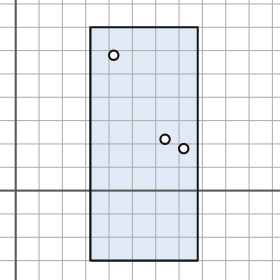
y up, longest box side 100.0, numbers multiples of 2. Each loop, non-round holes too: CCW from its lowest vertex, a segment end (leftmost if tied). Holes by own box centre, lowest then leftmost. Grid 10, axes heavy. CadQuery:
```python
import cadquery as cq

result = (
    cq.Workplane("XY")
    .moveTo(32.0, -30.0)
    .lineTo(78.0, -30.0)
    .lineTo(78.0, 70.0)
    .lineTo(32.0, 70.0)
    .close()
    .moveTo(72.0, 18.0)
    .circle(2.0)
    .moveTo(64.0, 22.0)
    .circle(2.0)
    .moveTo(42.0, 58.0)
    .circle(2.0)
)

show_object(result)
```